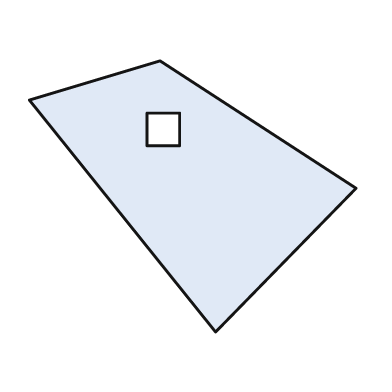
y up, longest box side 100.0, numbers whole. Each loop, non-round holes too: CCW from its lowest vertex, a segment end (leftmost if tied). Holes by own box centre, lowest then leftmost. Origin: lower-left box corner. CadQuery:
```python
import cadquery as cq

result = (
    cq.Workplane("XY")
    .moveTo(57.0, 0.0)
    .lineTo(100.0, 44.0)
    .lineTo(40.0, 83.0)
    .lineTo(0.0, 71.0)
    .close()
    .moveTo(36.0, 57.0)
    .lineTo(46.0, 57.0)
    .lineTo(46.0, 67.0)
    .lineTo(36.0, 67.0)
    .close()
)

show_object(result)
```